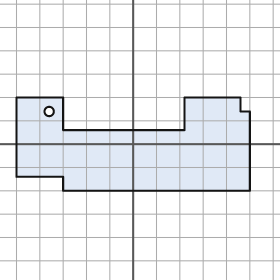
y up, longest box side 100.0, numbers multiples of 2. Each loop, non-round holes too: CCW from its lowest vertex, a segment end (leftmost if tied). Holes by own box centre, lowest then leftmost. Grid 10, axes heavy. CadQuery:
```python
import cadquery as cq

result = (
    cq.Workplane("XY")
    .moveTo(-30.0, -20.0)
    .lineTo(50.0, -20.0)
    .lineTo(50.0, 14.0)
    .lineTo(46.0, 14.0)
    .lineTo(46.0, 20.0)
    .lineTo(22.0, 20.0)
    .lineTo(22.0, 6.0)
    .lineTo(-30.0, 6.0)
    .lineTo(-30.0, 20.0)
    .lineTo(-50.0, 20.0)
    .lineTo(-50.0, -14.0)
    .lineTo(-30.0, -14.0)
    .close()
    .moveTo(-36.0, 14.0)
    .circle(2.0)
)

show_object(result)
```